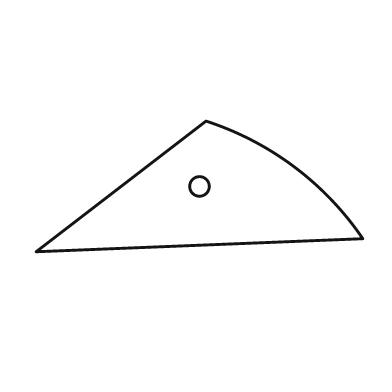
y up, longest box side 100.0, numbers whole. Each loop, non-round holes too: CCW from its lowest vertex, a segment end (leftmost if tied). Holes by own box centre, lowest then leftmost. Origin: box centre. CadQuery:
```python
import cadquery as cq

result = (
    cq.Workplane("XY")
    .moveTo(-50.0, -20.0)
    .lineTo(50.0, -16.0)
    .threePointArc((29.0, 6.0), (2.0, 20.0))
    .close()
    .moveTo(0.0, 0.0)
    .circle(3.0)
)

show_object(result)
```